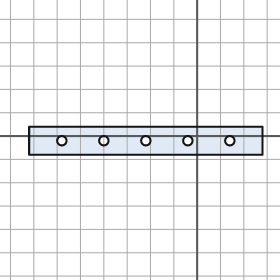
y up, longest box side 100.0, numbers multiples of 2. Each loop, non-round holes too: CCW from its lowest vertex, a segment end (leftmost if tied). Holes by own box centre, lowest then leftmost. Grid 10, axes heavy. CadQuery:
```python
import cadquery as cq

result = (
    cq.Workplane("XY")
    .moveTo(-72.0, -8.0)
    .lineTo(28.0, -8.0)
    .lineTo(28.0, 4.0)
    .lineTo(-72.0, 4.0)
    .close()
    .moveTo(-58.0, -2.0)
    .circle(2.0)
    .moveTo(-40.0, -2.0)
    .circle(2.0)
    .moveTo(-22.0, -2.0)
    .circle(2.0)
    .moveTo(-4.0, -2.0)
    .circle(2.0)
    .moveTo(14.0, -2.0)
    .circle(2.0)
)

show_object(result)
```